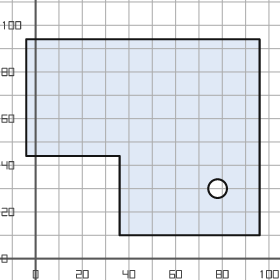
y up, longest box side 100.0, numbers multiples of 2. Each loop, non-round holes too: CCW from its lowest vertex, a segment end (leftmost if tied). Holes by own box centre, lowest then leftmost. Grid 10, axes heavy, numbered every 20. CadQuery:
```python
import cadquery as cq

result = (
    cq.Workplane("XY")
    .moveTo(36.0, 10.0)
    .lineTo(96.0, 10.0)
    .lineTo(96.0, 94.0)
    .lineTo(-4.0, 94.0)
    .lineTo(-4.0, 44.0)
    .lineTo(36.0, 44.0)
    .close()
    .moveTo(78.0, 30.0)
    .circle(4.0)
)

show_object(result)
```